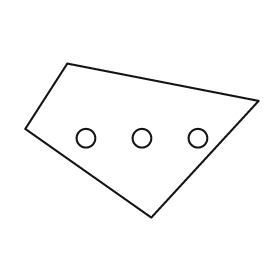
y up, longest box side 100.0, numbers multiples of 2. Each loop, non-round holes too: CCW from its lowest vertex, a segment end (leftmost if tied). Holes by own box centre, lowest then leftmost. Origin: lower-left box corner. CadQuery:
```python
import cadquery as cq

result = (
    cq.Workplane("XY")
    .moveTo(54.0, 0.0)
    .lineTo(100.0, 50.0)
    .lineTo(18.0, 66.0)
    .lineTo(0.0, 38.0)
    .close()
    .moveTo(26.0, 34.0)
    .circle(4.0)
    .moveTo(50.0, 34.0)
    .circle(4.0)
    .moveTo(74.0, 34.0)
    .circle(4.0)
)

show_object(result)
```